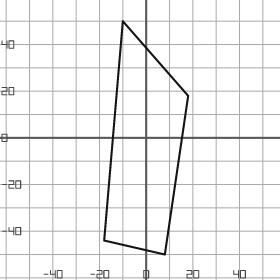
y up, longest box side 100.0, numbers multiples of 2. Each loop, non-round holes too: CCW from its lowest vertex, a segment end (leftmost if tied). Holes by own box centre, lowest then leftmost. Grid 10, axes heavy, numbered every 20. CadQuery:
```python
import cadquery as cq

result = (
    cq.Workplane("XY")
    .moveTo(8.0, -50.0)
    .lineTo(18.0, 18.0)
    .lineTo(-10.0, 50.0)
    .lineTo(-18.0, -44.0)
    .close()
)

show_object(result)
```